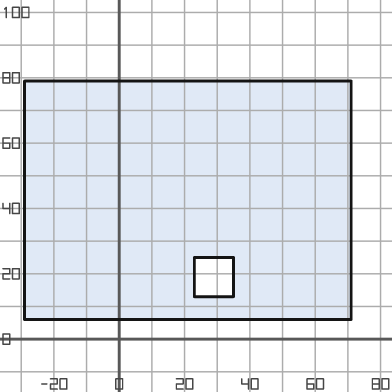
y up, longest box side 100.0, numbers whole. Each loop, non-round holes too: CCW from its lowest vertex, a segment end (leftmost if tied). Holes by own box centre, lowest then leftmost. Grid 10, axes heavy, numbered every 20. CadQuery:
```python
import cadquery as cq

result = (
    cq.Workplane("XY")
    .moveTo(-29.0, 6.0)
    .lineTo(71.0, 6.0)
    .lineTo(71.0, 79.0)
    .lineTo(-29.0, 79.0)
    .close()
    .moveTo(23.0, 13.0)
    .lineTo(35.0, 13.0)
    .lineTo(35.0, 25.0)
    .lineTo(23.0, 25.0)
    .close()
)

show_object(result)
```